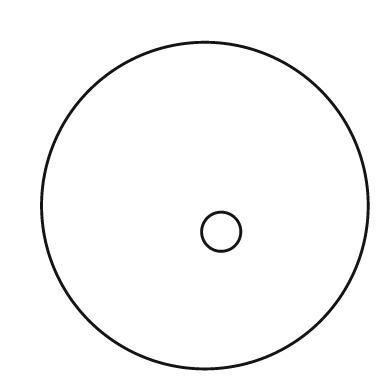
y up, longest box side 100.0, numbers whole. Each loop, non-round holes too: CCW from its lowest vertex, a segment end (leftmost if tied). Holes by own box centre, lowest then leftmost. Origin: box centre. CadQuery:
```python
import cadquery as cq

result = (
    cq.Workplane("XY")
    .moveTo(0.0, 0.0)
    .circle(50.0)
    .moveTo(5.0, -8.0)
    .circle(6.0)
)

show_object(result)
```